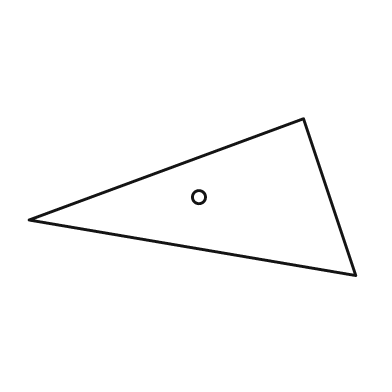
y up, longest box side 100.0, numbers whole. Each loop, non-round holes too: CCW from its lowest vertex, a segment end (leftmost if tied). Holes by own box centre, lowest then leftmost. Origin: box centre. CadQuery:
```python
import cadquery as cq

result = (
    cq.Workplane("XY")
    .moveTo(50.0, -24.0)
    .lineTo(34.0, 24.0)
    .lineTo(-50.0, -7.0)
    .close()
    .moveTo(2.0, 0.0)
    .circle(2.0)
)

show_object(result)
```